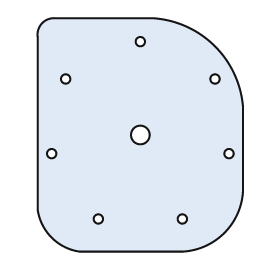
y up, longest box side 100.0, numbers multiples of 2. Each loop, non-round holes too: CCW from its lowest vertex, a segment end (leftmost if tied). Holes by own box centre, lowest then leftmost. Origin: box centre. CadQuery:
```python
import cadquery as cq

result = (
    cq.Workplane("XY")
    .moveTo(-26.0, -50.0)
    .lineTo(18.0, -50.0)
    .threePointArc((36.0, -42.0), (44.0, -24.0))
    .lineTo(44.0, 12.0)
    .threePointArc((32.0, 38.0), (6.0, 50.0))
    .lineTo(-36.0, 50.0)
    .threePointArc((-42.0, 48.0), (-44.0, 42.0))
    .lineTo(-44.0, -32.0)
    .threePointArc((-38.0, -44.0), (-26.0, -50.0))
    .close()
    .moveTo(-18.0, -36.0)
    .circle(2.0)
    .moveTo(18.0, -36.0)
    .circle(2.0)
    .moveTo(-38.0, -8.0)
    .circle(2.0)
    .moveTo(38.0, -8.0)
    .circle(2.0)
    .moveTo(0.0, 0.0)
    .circle(4.0)
    .moveTo(-32.0, 24.0)
    .circle(2.0)
    .moveTo(32.0, 24.0)
    .circle(2.0)
    .moveTo(0.0, 40.0)
    .circle(2.0)
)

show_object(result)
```